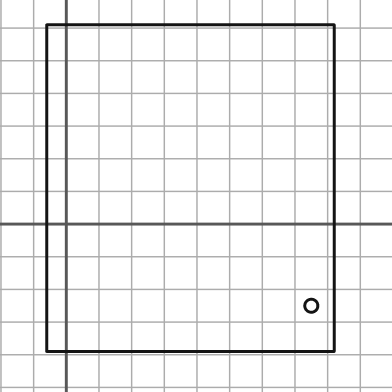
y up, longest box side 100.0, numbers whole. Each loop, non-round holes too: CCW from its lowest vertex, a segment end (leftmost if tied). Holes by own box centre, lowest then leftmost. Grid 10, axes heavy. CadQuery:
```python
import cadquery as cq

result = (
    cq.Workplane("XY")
    .moveTo(-6.0, -39.0)
    .lineTo(82.0, -39.0)
    .lineTo(82.0, 61.0)
    .lineTo(-6.0, 61.0)
    .close()
    .moveTo(75.0, -25.0)
    .circle(2.0)
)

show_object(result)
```